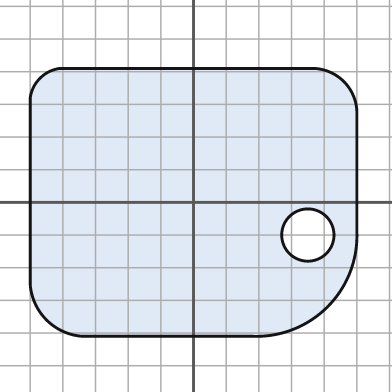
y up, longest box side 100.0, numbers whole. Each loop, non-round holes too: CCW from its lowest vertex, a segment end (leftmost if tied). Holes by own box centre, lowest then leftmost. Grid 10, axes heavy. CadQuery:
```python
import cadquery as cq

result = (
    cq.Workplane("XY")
    .moveTo(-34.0, -41.0)
    .lineTo(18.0, -41.0)
    .threePointArc((41.0, -32.0), (50.0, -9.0))
    .lineTo(50.0, 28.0)
    .threePointArc((46.0, 37.0), (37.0, 41.0))
    .lineTo(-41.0, 41.0)
    .threePointArc((-47.0, 38.0), (-50.0, 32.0))
    .lineTo(-50.0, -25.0)
    .threePointArc((-45.0, -36.0), (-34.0, -41.0))
    .close()
    .moveTo(35.0, -10.0)
    .circle(8.0)
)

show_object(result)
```